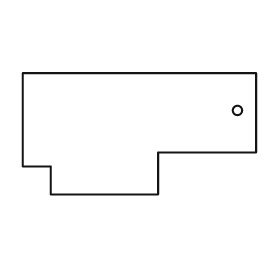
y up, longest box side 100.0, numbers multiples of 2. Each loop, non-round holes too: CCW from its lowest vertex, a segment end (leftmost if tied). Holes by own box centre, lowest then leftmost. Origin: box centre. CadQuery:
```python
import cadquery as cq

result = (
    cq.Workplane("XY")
    .moveTo(-38.0, -26.0)
    .lineTo(8.0, -26.0)
    .lineTo(8.0, -8.0)
    .lineTo(50.0, -8.0)
    .lineTo(50.0, 26.0)
    .lineTo(-50.0, 26.0)
    .lineTo(-50.0, -14.0)
    .lineTo(-38.0, -14.0)
    .close()
    .moveTo(42.0, 10.0)
    .circle(2.0)
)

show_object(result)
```